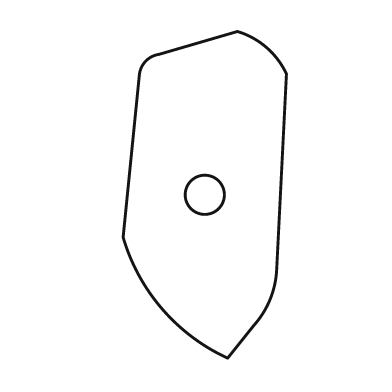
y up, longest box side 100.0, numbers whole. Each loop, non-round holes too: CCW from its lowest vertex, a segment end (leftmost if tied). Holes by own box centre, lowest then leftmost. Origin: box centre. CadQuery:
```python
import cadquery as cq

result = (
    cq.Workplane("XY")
    .moveTo(7.0, -50.0)
    .lineTo(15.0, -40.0)
    .threePointArc((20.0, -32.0), (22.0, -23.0))
    .lineTo(25.0, 37.0)
    .threePointArc((19.0, 45.0), (10.0, 50.0))
    .lineTo(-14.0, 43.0)
    .threePointArc((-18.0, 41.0), (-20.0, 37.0))
    .lineTo(-25.0, -13.0)
    .threePointArc((-13.0, -35.0), (7.0, -50.0))
    .close()
    .moveTo(0.0, 0.0)
    .circle(6.0)
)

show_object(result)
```